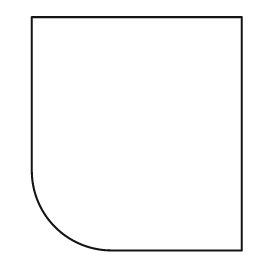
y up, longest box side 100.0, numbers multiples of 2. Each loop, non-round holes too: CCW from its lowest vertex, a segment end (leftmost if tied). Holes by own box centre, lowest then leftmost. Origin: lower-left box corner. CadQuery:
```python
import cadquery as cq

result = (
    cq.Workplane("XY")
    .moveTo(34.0, 0.0)
    .lineTo(90.0, 0.0)
    .lineTo(90.0, 100.0)
    .lineTo(0.0, 100.0)
    .lineTo(0.0, 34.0)
    .threePointArc((10.0, 10.0), (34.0, 0.0))
    .close()
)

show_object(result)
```